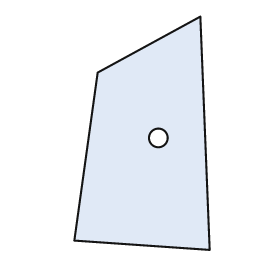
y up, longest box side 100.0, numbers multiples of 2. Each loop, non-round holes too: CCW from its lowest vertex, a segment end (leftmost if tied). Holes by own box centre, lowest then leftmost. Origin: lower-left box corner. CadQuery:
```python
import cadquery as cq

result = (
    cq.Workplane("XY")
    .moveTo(58.0, 0.0)
    .lineTo(54.0, 100.0)
    .lineTo(10.0, 76.0)
    .lineTo(0.0, 4.0)
    .close()
    .moveTo(36.0, 48.0)
    .circle(4.0)
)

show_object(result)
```